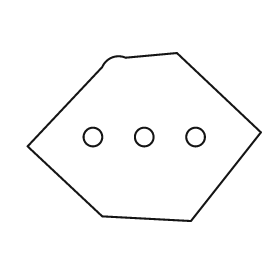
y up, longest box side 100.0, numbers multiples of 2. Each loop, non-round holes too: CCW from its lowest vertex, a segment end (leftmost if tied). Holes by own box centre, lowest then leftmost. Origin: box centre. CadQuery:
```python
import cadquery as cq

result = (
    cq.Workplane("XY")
    .moveTo(20.0, -36.0)
    .lineTo(50.0, 2.0)
    .lineTo(14.0, 36.0)
    .lineTo(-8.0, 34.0)
    .threePointArc((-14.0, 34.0), (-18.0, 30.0))
    .lineTo(-50.0, -4.0)
    .lineTo(-18.0, -34.0)
    .close()
    .moveTo(-22.0, 0.0)
    .circle(4.0)
    .moveTo(0.0, 0.0)
    .circle(4.0)
    .moveTo(22.0, 0.0)
    .circle(4.0)
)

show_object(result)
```